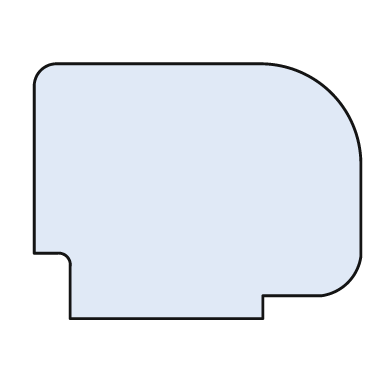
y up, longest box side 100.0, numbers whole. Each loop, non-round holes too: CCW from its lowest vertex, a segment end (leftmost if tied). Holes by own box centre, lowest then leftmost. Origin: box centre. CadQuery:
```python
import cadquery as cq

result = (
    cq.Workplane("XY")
    .moveTo(-39.0, -39.0)
    .lineTo(20.0, -39.0)
    .lineTo(20.0, -32.0)
    .lineTo(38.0, -32.0)
    .threePointArc((46.0, -28.0), (50.0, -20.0))
    .lineTo(50.0, 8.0)
    .threePointArc((41.0, 30.0), (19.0, 39.0))
    .lineTo(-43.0, 39.0)
    .threePointArc((-48.0, 37.0), (-50.0, 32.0))
    .lineTo(-50.0, -19.0)
    .lineTo(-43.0, -19.0)
    .threePointArc((-40.0, -20.0), (-39.0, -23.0))
    .close()
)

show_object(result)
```